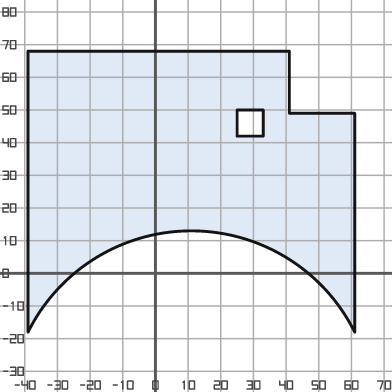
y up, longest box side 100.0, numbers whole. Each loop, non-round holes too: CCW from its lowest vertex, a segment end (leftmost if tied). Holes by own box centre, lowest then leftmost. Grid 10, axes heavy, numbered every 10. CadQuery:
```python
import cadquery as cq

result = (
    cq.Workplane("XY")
    .moveTo(-39.0, -18.0)
    .threePointArc((11.0, 13.0), (61.0, -18.0))
    .lineTo(61.0, 49.0)
    .lineTo(41.0, 49.0)
    .lineTo(41.0, 68.0)
    .lineTo(-39.0, 68.0)
    .close()
    .moveTo(25.0, 42.0)
    .lineTo(33.0, 42.0)
    .lineTo(33.0, 50.0)
    .lineTo(25.0, 50.0)
    .close()
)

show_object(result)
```